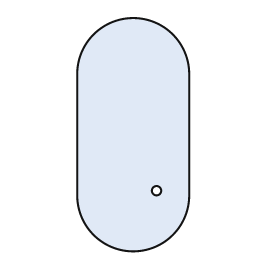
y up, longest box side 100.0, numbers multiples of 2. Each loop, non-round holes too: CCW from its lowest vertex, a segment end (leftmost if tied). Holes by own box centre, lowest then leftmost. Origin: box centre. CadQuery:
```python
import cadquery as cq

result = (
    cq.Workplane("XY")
    .moveTo(-24.0, -26.0)
    .threePointArc((0.0, -50.0), (24.0, -26.0))
    .lineTo(24.0, 26.0)
    .threePointArc((0.0, 50.0), (-24.0, 26.0))
    .close()
    .moveTo(10.0, -24.0)
    .circle(2.0)
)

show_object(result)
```